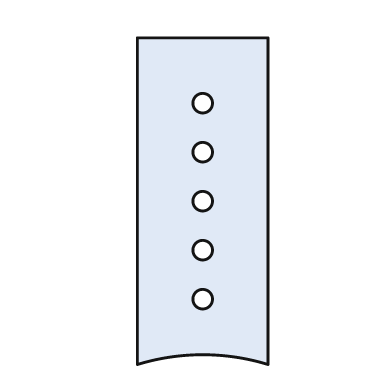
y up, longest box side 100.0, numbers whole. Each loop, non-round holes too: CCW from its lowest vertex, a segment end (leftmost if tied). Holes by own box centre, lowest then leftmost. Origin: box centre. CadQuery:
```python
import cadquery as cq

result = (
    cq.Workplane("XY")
    .moveTo(-20.0, -50.0)
    .threePointArc((0.0, -47.0), (20.0, -50.0))
    .lineTo(20.0, 50.0)
    .lineTo(-20.0, 50.0)
    .close()
    .moveTo(0.0, -30.0)
    .circle(3.0)
    .moveTo(0.0, -15.0)
    .circle(3.0)
    .moveTo(0.0, 0.0)
    .circle(3.0)
    .moveTo(0.0, 15.0)
    .circle(3.0)
    .moveTo(0.0, 30.0)
    .circle(3.0)
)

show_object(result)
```